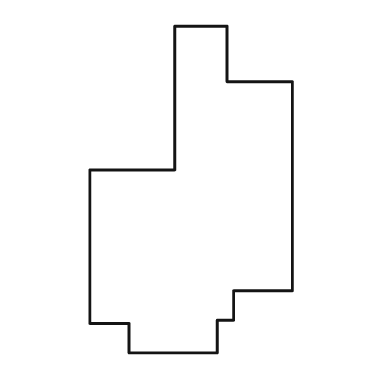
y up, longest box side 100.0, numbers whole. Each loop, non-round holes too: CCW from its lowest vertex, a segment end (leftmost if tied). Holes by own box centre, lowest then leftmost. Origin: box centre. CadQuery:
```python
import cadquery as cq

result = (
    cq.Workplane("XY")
    .moveTo(-19.0, -50.0)
    .lineTo(8.0, -50.0)
    .lineTo(8.0, -40.0)
    .lineTo(13.0, -40.0)
    .lineTo(13.0, -31.0)
    .lineTo(31.0, -31.0)
    .lineTo(31.0, 33.0)
    .lineTo(11.0, 33.0)
    .lineTo(11.0, 50.0)
    .lineTo(-5.0, 50.0)
    .lineTo(-5.0, 6.0)
    .lineTo(-31.0, 6.0)
    .lineTo(-31.0, -41.0)
    .lineTo(-19.0, -41.0)
    .close()
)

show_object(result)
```